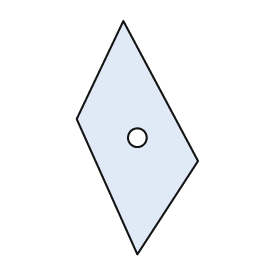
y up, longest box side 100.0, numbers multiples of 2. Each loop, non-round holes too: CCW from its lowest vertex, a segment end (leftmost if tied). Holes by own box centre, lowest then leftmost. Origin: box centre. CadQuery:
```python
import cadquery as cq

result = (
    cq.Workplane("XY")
    .moveTo(0.0, -50.0)
    .lineTo(26.0, -10.0)
    .lineTo(-6.0, 50.0)
    .lineTo(-26.0, 8.0)
    .close()
    .moveTo(0.0, 0.0)
    .circle(4.0)
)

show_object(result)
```